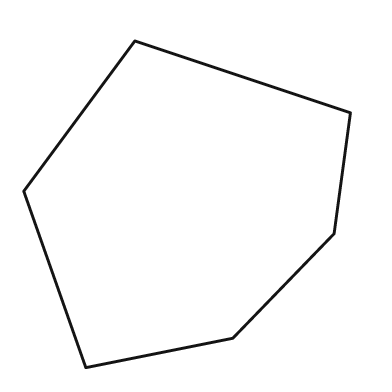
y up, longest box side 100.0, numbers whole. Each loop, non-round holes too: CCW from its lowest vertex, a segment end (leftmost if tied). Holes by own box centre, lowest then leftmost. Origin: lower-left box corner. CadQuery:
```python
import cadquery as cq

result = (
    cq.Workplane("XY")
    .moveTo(19.0, 0.0)
    .lineTo(64.0, 9.0)
    .lineTo(95.0, 41.0)
    .lineTo(100.0, 78.0)
    .lineTo(34.0, 100.0)
    .lineTo(0.0, 54.0)
    .close()
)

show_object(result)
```